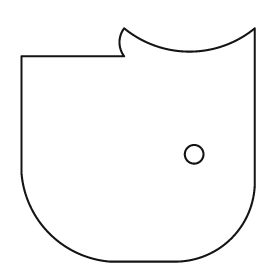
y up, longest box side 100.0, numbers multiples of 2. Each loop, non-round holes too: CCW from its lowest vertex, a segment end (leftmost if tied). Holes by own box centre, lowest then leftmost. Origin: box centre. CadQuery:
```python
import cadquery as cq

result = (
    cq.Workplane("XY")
    .moveTo(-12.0, -50.0)
    .lineTo(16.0, -50.0)
    .threePointArc((40.0, -40.0), (50.0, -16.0))
    .lineTo(50.0, 50.0)
    .threePointArc((22.0, 40.0), (-6.0, 50.0))
    .threePointArc((-8.0, 44.0), (-6.0, 38.0))
    .lineTo(-50.0, 38.0)
    .lineTo(-50.0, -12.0)
    .threePointArc((-38.0, -38.0), (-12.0, -50.0))
    .close()
    .moveTo(24.0, -4.0)
    .circle(4.0)
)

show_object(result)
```